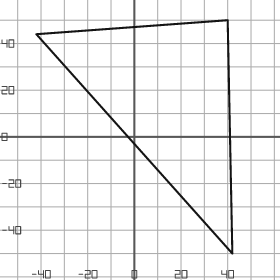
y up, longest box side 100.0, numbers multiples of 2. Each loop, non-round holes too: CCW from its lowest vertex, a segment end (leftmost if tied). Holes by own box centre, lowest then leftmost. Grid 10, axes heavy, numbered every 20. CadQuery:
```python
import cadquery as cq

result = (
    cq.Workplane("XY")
    .moveTo(42.0, -50.0)
    .lineTo(40.0, 50.0)
    .lineTo(-42.0, 44.0)
    .close()
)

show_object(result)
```